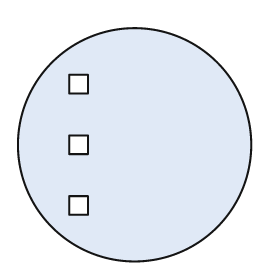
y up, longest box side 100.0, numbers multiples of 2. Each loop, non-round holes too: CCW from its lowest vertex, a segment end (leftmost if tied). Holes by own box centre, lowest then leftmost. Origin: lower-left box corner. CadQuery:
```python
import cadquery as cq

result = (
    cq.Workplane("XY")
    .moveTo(50.0, 50.0)
    .circle(50.0)
    .moveTo(22.0, 20.0)
    .lineTo(30.0, 20.0)
    .lineTo(30.0, 28.0)
    .lineTo(22.0, 28.0)
    .close()
    .moveTo(22.0, 46.0)
    .lineTo(30.0, 46.0)
    .lineTo(30.0, 54.0)
    .lineTo(22.0, 54.0)
    .close()
    .moveTo(22.0, 72.0)
    .lineTo(30.0, 72.0)
    .lineTo(30.0, 80.0)
    .lineTo(22.0, 80.0)
    .close()
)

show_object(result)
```